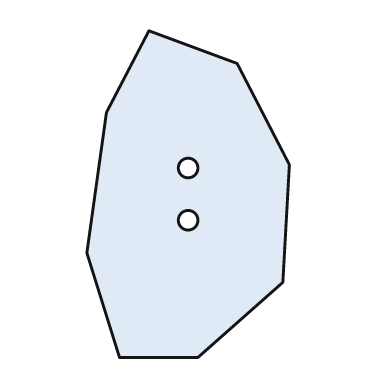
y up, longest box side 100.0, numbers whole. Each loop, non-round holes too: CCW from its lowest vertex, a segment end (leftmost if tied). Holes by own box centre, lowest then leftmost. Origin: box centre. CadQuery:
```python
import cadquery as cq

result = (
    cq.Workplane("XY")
    .moveTo(-21.0, -50.0)
    .lineTo(3.0, -50.0)
    .lineTo(29.0, -27.0)
    .lineTo(31.0, 9.0)
    .lineTo(15.0, 40.0)
    .lineTo(-12.0, 50.0)
    .lineTo(-25.0, 25.0)
    .lineTo(-31.0, -18.0)
    .close()
    .moveTo(0.0, -8.0)
    .circle(3.0)
    .moveTo(0.0, 8.0)
    .circle(3.0)
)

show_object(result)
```